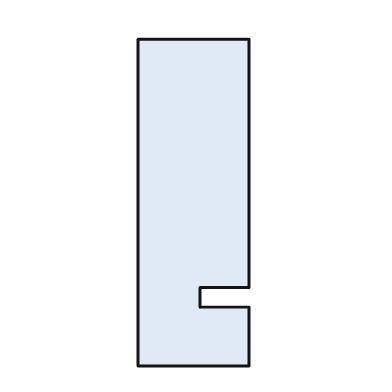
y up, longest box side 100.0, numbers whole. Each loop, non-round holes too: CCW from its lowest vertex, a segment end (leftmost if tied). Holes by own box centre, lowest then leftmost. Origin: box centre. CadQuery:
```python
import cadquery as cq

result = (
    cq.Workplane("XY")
    .moveTo(-17.0, -50.0)
    .lineTo(17.0, -50.0)
    .lineTo(17.0, -32.0)
    .lineTo(2.0, -32.0)
    .lineTo(2.0, -26.0)
    .lineTo(17.0, -26.0)
    .lineTo(17.0, 50.0)
    .lineTo(-17.0, 50.0)
    .close()
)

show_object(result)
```